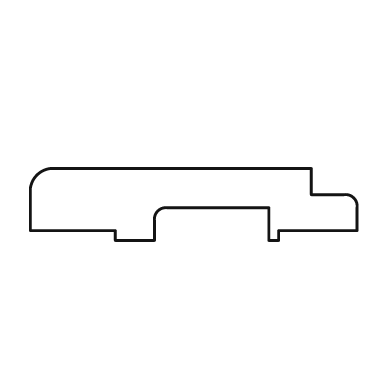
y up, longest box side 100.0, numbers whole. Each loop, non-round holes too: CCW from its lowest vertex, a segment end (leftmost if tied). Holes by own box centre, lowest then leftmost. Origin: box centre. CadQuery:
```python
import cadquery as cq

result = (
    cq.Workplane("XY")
    .moveTo(-24.0, -11.0)
    .lineTo(-12.0, -11.0)
    .lineTo(-12.0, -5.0)
    .threePointArc((-11.0, -2.0), (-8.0, -1.0))
    .lineTo(23.0, -1.0)
    .lineTo(23.0, -11.0)
    .lineTo(26.0, -11.0)
    .lineTo(26.0, -8.0)
    .lineTo(50.0, -8.0)
    .lineTo(50.0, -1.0)
    .threePointArc((49.0, 2.0), (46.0, 3.0))
    .lineTo(36.0, 3.0)
    .lineTo(36.0, 11.0)
    .lineTo(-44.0, 11.0)
    .threePointArc((-48.0, 9.0), (-50.0, 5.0))
    .lineTo(-50.0, -8.0)
    .lineTo(-24.0, -8.0)
    .close()
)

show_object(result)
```